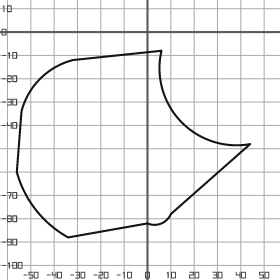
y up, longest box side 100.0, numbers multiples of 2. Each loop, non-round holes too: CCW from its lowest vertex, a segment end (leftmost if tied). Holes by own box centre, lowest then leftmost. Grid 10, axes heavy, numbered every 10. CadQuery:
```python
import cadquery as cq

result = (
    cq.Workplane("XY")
    .moveTo(-34.0, -88.0)
    .lineTo(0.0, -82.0)
    .threePointArc((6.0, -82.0), (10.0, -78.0))
    .lineTo(44.0, -48.0)
    .threePointArc((14.0, -38.0), (6.0, -8.0))
    .lineTo(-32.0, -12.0)
    .threePointArc((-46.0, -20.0), (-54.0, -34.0))
    .lineTo(-56.0, -60.0)
    .threePointArc((-48.0, -76.0), (-34.0, -88.0))
    .close()
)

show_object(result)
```